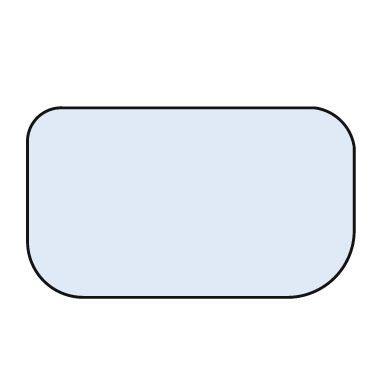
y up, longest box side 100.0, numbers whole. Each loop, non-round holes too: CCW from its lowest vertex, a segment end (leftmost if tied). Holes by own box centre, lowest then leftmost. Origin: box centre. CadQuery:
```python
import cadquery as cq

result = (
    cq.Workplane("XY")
    .moveTo(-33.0, -29.0)
    .lineTo(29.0, -29.0)
    .threePointArc((44.0, -23.0), (50.0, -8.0))
    .lineTo(50.0, 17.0)
    .threePointArc((46.0, 25.0), (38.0, 29.0))
    .lineTo(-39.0, 29.0)
    .threePointArc((-47.0, 26.0), (-50.0, 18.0))
    .lineTo(-50.0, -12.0)
    .threePointArc((-45.0, -24.0), (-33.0, -29.0))
    .close()
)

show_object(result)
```